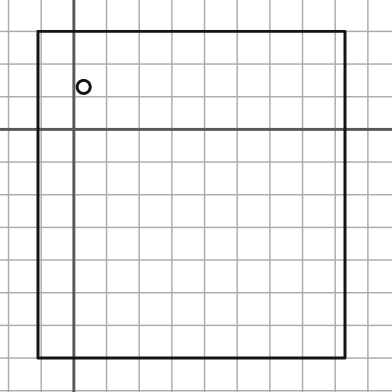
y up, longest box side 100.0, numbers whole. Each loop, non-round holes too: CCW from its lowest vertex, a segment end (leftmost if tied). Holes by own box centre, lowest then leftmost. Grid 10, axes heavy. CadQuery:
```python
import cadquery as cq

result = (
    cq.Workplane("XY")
    .moveTo(-11.0, -70.0)
    .lineTo(83.0, -70.0)
    .lineTo(83.0, 30.0)
    .lineTo(-11.0, 30.0)
    .close()
    .moveTo(3.0, 13.0)
    .circle(2.0)
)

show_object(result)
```